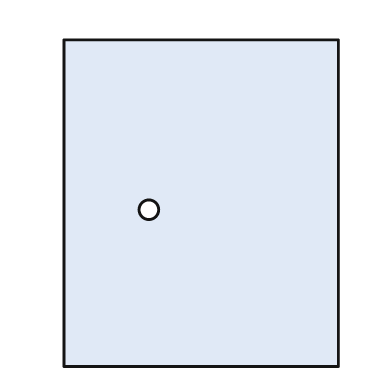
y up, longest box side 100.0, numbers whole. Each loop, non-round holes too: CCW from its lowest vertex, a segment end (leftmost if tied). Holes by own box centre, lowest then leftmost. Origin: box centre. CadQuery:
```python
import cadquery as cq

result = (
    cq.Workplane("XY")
    .moveTo(-42.0, -50.0)
    .lineTo(42.0, -50.0)
    .lineTo(42.0, 50.0)
    .lineTo(-42.0, 50.0)
    .close()
    .moveTo(-16.0, -2.0)
    .circle(3.0)
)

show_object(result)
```